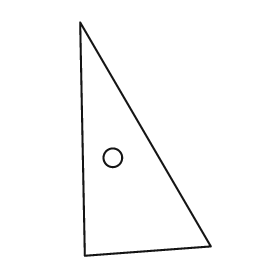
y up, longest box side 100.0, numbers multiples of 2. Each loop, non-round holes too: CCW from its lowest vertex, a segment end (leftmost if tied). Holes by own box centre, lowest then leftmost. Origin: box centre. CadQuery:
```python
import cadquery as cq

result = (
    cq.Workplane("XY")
    .moveTo(-26.0, -50.0)
    .lineTo(28.0, -46.0)
    .lineTo(-28.0, 50.0)
    .close()
    .moveTo(-14.0, -8.0)
    .circle(4.0)
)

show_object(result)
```